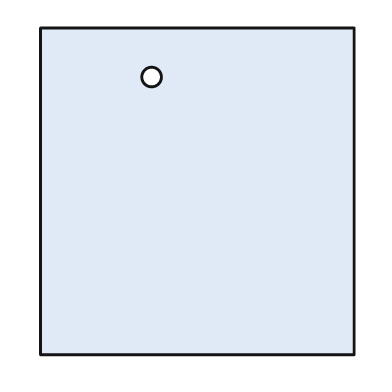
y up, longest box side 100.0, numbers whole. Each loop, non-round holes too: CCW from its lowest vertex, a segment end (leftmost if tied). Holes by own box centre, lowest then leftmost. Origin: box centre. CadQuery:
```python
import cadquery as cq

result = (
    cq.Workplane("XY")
    .moveTo(-48.0, -50.0)
    .lineTo(48.0, -50.0)
    .lineTo(48.0, 50.0)
    .lineTo(-48.0, 50.0)
    .close()
    .moveTo(-14.0, 35.0)
    .circle(3.0)
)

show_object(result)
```